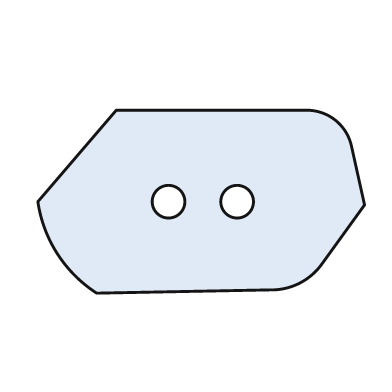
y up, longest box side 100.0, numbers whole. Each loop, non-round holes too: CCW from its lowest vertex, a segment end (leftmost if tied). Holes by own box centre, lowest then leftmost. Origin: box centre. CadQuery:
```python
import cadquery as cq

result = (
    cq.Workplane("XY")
    .moveTo(-32.0, -28.0)
    .lineTo(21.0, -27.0)
    .threePointArc((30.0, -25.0), (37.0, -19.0))
    .lineTo(50.0, -1.0)
    .lineTo(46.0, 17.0)
    .threePointArc((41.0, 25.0), (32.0, 28.0))
    .lineTo(-26.0, 28.0)
    .lineTo(-50.0, 0.0)
    .threePointArc((-44.0, -16.0), (-32.0, -28.0))
    .close()
    .moveTo(-10.0, 0.0)
    .circle(5.0)
    .moveTo(11.0, 0.0)
    .circle(5.0)
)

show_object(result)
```